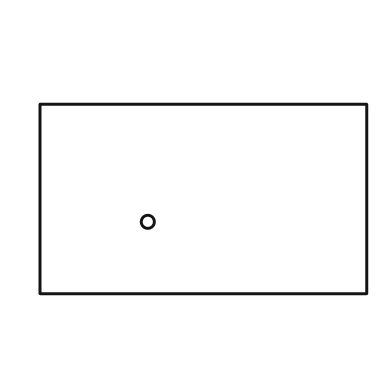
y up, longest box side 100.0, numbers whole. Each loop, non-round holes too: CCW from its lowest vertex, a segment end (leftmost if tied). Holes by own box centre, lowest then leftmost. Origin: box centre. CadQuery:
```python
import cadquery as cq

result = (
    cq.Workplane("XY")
    .moveTo(-50.0, -29.0)
    .lineTo(50.0, -29.0)
    .lineTo(50.0, 29.0)
    .lineTo(-50.0, 29.0)
    .close()
    .moveTo(-17.0, -7.0)
    .circle(2.0)
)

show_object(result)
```